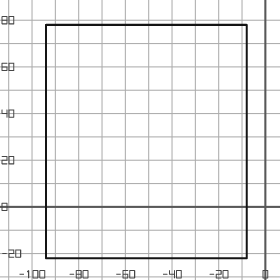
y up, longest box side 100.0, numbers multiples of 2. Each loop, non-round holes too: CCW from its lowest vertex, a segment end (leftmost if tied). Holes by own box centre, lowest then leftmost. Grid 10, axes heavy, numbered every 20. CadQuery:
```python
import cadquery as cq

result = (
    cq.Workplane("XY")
    .moveTo(-94.0, -22.0)
    .lineTo(-8.0, -22.0)
    .lineTo(-8.0, 78.0)
    .lineTo(-94.0, 78.0)
    .close()
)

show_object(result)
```